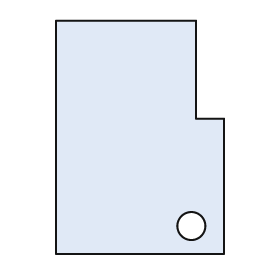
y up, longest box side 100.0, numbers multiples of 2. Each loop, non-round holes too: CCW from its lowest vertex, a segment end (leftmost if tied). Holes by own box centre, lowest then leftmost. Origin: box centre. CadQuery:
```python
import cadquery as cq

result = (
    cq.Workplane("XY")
    .moveTo(-36.0, -50.0)
    .lineTo(36.0, -50.0)
    .lineTo(36.0, 8.0)
    .lineTo(24.0, 8.0)
    .lineTo(24.0, 50.0)
    .lineTo(-36.0, 50.0)
    .close()
    .moveTo(22.0, -38.0)
    .circle(6.0)
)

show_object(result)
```